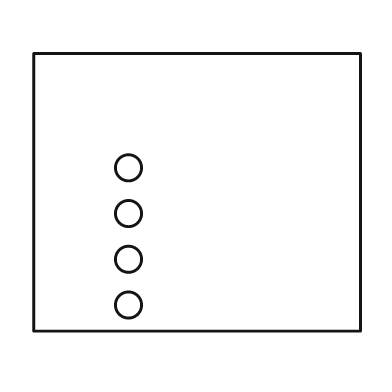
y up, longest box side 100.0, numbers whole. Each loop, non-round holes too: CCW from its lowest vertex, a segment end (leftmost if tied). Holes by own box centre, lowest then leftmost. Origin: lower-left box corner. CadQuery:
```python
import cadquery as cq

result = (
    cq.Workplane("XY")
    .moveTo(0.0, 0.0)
    .lineTo(100.0, 0.0)
    .lineTo(100.0, 85.0)
    .lineTo(0.0, 85.0)
    .close()
    .moveTo(29.0, 8.0)
    .circle(4.0)
    .moveTo(29.0, 22.0)
    .circle(4.0)
    .moveTo(29.0, 36.0)
    .circle(4.0)
    .moveTo(29.0, 50.0)
    .circle(4.0)
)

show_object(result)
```